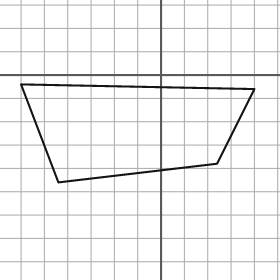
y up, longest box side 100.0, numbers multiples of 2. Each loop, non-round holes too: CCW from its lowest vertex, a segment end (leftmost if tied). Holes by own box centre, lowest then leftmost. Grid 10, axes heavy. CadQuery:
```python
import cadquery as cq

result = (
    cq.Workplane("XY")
    .moveTo(-44.0, -46.0)
    .lineTo(24.0, -38.0)
    .lineTo(40.0, -6.0)
    .lineTo(-60.0, -4.0)
    .close()
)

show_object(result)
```